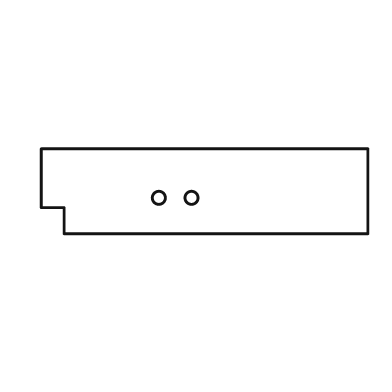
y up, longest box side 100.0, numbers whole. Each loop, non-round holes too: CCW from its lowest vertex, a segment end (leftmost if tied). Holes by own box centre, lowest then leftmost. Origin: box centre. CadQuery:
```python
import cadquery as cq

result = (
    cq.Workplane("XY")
    .moveTo(-43.0, -13.0)
    .lineTo(50.0, -13.0)
    .lineTo(50.0, 13.0)
    .lineTo(-50.0, 13.0)
    .lineTo(-50.0, -5.0)
    .lineTo(-43.0, -5.0)
    .close()
    .moveTo(-14.0, -2.0)
    .circle(2.0)
    .moveTo(-4.0, -2.0)
    .circle(2.0)
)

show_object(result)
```